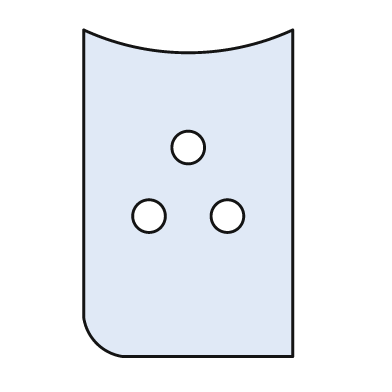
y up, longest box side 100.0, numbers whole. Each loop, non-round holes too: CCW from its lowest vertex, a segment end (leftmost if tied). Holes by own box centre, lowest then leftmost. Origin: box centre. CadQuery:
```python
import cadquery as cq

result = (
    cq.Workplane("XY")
    .moveTo(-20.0, -50.0)
    .lineTo(32.0, -50.0)
    .lineTo(32.0, 50.0)
    .threePointArc((0.0, 43.0), (-32.0, 50.0))
    .lineTo(-32.0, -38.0)
    .threePointArc((-28.0, -46.0), (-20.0, -50.0))
    .close()
    .moveTo(-12.0, -7.0)
    .circle(5.0)
    .moveTo(12.0, -7.0)
    .circle(5.0)
    .moveTo(0.0, 14.0)
    .circle(5.0)
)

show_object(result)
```